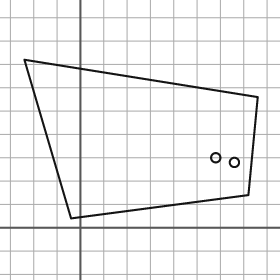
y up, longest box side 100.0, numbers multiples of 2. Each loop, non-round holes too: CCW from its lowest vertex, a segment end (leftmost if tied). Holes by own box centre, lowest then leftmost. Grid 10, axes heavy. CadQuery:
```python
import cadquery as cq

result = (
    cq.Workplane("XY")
    .moveTo(-4.0, 4.0)
    .lineTo(72.0, 14.0)
    .lineTo(76.0, 56.0)
    .lineTo(-24.0, 72.0)
    .close()
    .moveTo(66.0, 28.0)
    .circle(2.0)
    .moveTo(58.0, 30.0)
    .circle(2.0)
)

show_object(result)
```